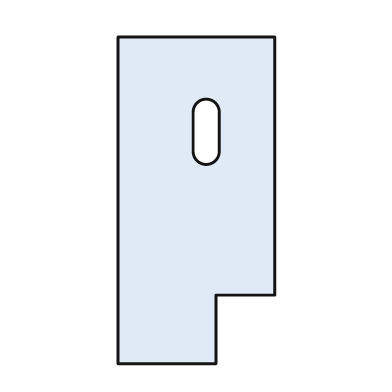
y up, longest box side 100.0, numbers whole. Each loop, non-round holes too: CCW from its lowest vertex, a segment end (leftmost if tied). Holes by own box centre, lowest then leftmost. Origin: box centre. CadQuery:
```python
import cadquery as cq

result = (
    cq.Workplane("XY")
    .moveTo(-24.0, -50.0)
    .lineTo(6.0, -50.0)
    .lineTo(6.0, -29.0)
    .lineTo(24.0, -29.0)
    .lineTo(24.0, 50.0)
    .lineTo(-24.0, 50.0)
    .close()
    .moveTo(-1.0, 15.0)
    .threePointArc((3.0, 11.0), (7.0, 15.0))
    .lineTo(7.0, 27.0)
    .threePointArc((3.0, 31.0), (-1.0, 27.0))
    .close()
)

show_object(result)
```